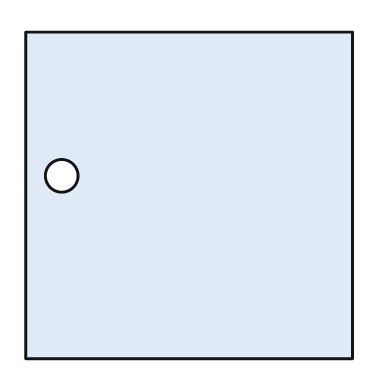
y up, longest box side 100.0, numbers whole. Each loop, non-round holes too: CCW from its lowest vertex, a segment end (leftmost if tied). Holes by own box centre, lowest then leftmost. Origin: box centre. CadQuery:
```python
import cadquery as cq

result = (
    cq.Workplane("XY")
    .moveTo(-50.0, -50.0)
    .lineTo(50.0, -50.0)
    .lineTo(50.0, 50.0)
    .lineTo(-50.0, 50.0)
    .close()
    .moveTo(-39.0, 6.0)
    .circle(5.0)
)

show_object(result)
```